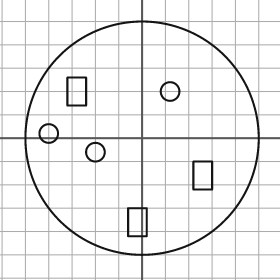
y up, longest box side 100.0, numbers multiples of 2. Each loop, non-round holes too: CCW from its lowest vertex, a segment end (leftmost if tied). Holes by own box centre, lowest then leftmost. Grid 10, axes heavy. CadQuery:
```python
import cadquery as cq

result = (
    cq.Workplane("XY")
    .moveTo(0.0, 0.0)
    .circle(50.0)
    .moveTo(-6.0, -42.0)
    .lineTo(2.0, -42.0)
    .lineTo(2.0, -30.0)
    .lineTo(-6.0, -30.0)
    .close()
    .moveTo(22.0, -22.0)
    .lineTo(30.0, -22.0)
    .lineTo(30.0, -10.0)
    .lineTo(22.0, -10.0)
    .close()
    .moveTo(-20.0, -6.0)
    .circle(4.0)
    .moveTo(-40.0, 2.0)
    .circle(4.0)
    .moveTo(-32.0, 14.0)
    .lineTo(-24.0, 14.0)
    .lineTo(-24.0, 26.0)
    .lineTo(-32.0, 26.0)
    .close()
    .moveTo(12.0, 20.0)
    .circle(4.0)
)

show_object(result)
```